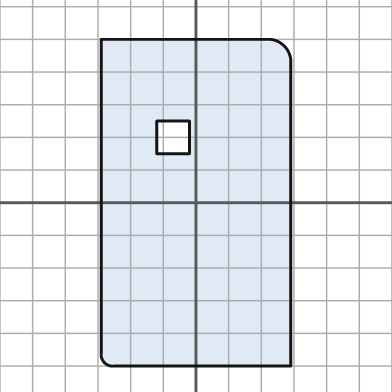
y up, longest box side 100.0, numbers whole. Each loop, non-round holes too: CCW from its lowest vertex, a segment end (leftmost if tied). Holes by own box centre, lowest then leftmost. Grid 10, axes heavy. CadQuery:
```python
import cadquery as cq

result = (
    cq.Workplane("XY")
    .moveTo(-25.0, -50.0)
    .lineTo(29.0, -50.0)
    .lineTo(29.0, 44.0)
    .threePointArc((27.0, 48.0), (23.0, 50.0))
    .lineTo(-29.0, 50.0)
    .lineTo(-29.0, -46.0)
    .threePointArc((-28.0, -49.0), (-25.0, -50.0))
    .close()
    .moveTo(-12.0, 15.0)
    .lineTo(-2.0, 15.0)
    .lineTo(-2.0, 25.0)
    .lineTo(-12.0, 25.0)
    .close()
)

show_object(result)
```